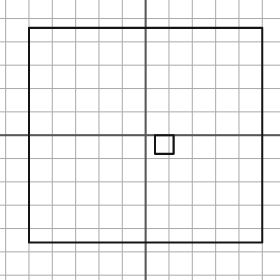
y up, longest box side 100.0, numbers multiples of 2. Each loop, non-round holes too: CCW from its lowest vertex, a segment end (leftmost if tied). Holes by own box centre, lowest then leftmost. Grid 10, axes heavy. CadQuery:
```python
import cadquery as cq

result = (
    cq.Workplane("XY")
    .moveTo(-50.0, -46.0)
    .lineTo(50.0, -46.0)
    .lineTo(50.0, 46.0)
    .lineTo(-50.0, 46.0)
    .close()
    .moveTo(4.0, -8.0)
    .lineTo(12.0, -8.0)
    .lineTo(12.0, 0.0)
    .lineTo(4.0, 0.0)
    .close()
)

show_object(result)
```